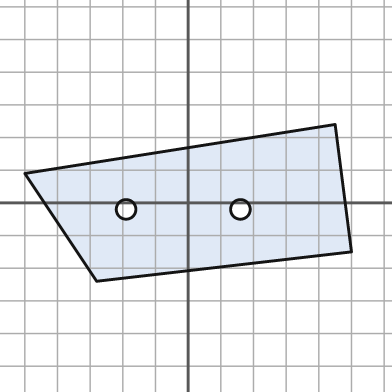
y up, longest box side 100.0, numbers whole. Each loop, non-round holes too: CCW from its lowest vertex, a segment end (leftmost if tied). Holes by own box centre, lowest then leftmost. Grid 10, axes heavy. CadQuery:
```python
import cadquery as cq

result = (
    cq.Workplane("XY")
    .moveTo(-28.0, -24.0)
    .lineTo(50.0, -15.0)
    .lineTo(45.0, 24.0)
    .lineTo(-50.0, 9.0)
    .close()
    .moveTo(-19.0, -2.0)
    .circle(3.0)
    .moveTo(16.0, -2.0)
    .circle(3.0)
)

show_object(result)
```